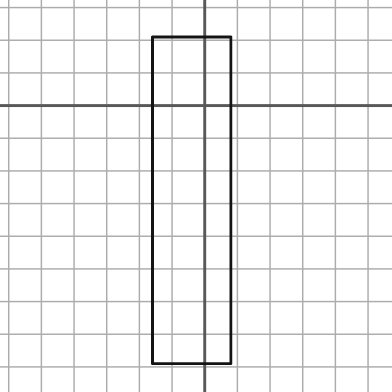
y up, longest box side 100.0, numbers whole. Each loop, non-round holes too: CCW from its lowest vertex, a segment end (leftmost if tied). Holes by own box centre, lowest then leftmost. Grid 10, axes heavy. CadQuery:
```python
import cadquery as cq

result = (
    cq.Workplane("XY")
    .moveTo(-16.0, -79.0)
    .lineTo(8.0, -79.0)
    .lineTo(8.0, 21.0)
    .lineTo(-16.0, 21.0)
    .close()
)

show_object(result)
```